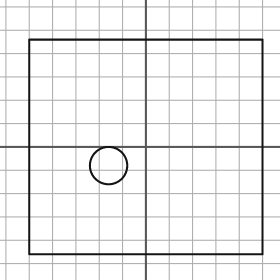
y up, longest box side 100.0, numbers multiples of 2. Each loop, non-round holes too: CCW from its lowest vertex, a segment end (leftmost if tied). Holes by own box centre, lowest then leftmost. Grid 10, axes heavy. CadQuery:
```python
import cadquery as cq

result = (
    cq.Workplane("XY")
    .moveTo(-50.0, -46.0)
    .lineTo(50.0, -46.0)
    .lineTo(50.0, 46.0)
    .lineTo(-50.0, 46.0)
    .close()
    .moveTo(-16.0, -8.0)
    .circle(8.0)
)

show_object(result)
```